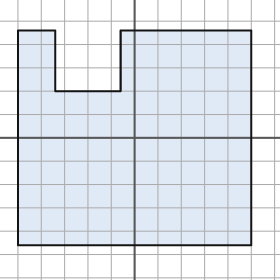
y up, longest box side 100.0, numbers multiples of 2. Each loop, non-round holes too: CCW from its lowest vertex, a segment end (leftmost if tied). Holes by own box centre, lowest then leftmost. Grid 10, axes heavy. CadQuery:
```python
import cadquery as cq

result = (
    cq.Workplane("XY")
    .moveTo(-50.0, -46.0)
    .lineTo(50.0, -46.0)
    .lineTo(50.0, 46.0)
    .lineTo(-6.0, 46.0)
    .lineTo(-6.0, 20.0)
    .lineTo(-34.0, 20.0)
    .lineTo(-34.0, 46.0)
    .lineTo(-50.0, 46.0)
    .close()
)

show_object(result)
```